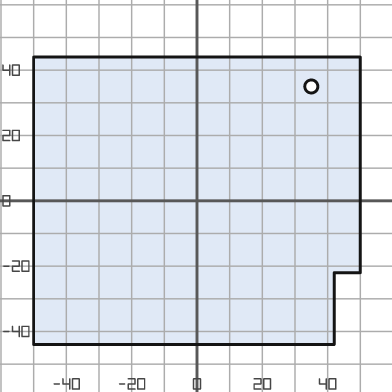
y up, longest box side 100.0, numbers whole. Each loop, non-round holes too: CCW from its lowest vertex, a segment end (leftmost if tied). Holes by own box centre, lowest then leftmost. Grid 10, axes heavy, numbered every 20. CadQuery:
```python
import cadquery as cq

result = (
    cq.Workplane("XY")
    .moveTo(-50.0, -44.0)
    .lineTo(42.0, -44.0)
    .lineTo(42.0, -22.0)
    .lineTo(50.0, -22.0)
    .lineTo(50.0, 44.0)
    .lineTo(-50.0, 44.0)
    .close()
    .moveTo(35.0, 35.0)
    .circle(2.0)
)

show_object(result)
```